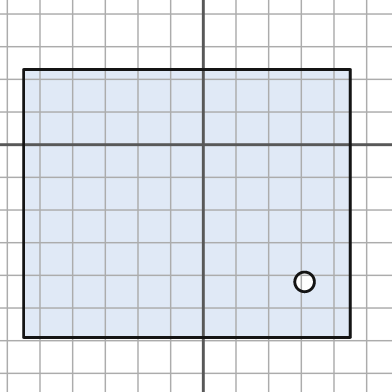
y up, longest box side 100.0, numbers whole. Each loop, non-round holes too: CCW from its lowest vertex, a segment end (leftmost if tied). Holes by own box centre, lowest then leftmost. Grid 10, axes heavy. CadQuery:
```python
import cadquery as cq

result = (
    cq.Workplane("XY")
    .moveTo(-55.0, -59.0)
    .lineTo(45.0, -59.0)
    .lineTo(45.0, 23.0)
    .lineTo(-55.0, 23.0)
    .close()
    .moveTo(31.0, -42.0)
    .circle(3.0)
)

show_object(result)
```